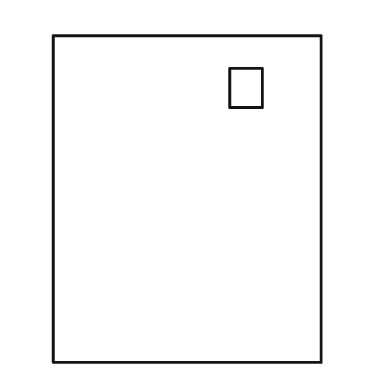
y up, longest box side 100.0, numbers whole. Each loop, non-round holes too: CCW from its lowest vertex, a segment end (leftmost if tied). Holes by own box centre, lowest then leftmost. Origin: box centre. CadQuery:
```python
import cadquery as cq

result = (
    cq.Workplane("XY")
    .moveTo(-41.0, -50.0)
    .lineTo(41.0, -50.0)
    .lineTo(41.0, 50.0)
    .lineTo(-41.0, 50.0)
    .close()
    .moveTo(13.0, 28.0)
    .lineTo(23.0, 28.0)
    .lineTo(23.0, 40.0)
    .lineTo(13.0, 40.0)
    .close()
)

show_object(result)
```